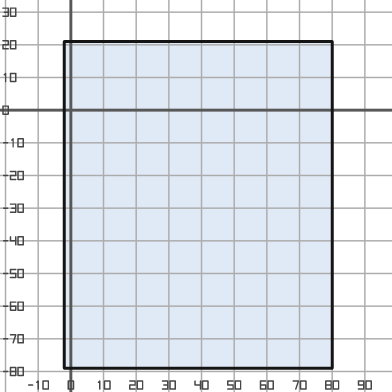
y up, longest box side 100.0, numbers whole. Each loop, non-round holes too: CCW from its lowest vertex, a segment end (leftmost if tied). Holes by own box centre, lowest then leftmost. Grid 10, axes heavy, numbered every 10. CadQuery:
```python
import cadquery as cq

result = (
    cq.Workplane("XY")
    .moveTo(-2.0, -79.0)
    .lineTo(80.0, -79.0)
    .lineTo(80.0, 21.0)
    .lineTo(-2.0, 21.0)
    .close()
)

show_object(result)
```